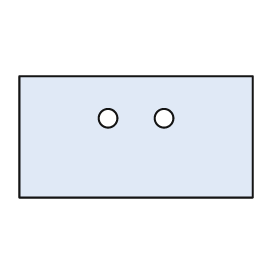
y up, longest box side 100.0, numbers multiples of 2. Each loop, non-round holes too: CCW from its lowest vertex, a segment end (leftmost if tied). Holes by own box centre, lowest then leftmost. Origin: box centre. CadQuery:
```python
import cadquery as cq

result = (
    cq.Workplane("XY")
    .moveTo(-50.0, -26.0)
    .lineTo(50.0, -26.0)
    .lineTo(50.0, 26.0)
    .lineTo(-50.0, 26.0)
    .close()
    .moveTo(-12.0, 8.0)
    .circle(4.0)
    .moveTo(12.0, 8.0)
    .circle(4.0)
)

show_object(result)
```